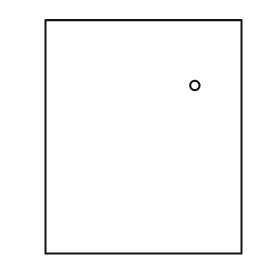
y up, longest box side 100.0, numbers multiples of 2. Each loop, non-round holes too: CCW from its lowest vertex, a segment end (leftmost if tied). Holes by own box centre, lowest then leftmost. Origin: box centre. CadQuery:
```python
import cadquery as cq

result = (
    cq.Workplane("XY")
    .moveTo(-42.0, -50.0)
    .lineTo(42.0, -50.0)
    .lineTo(42.0, 50.0)
    .lineTo(-42.0, 50.0)
    .close()
    .moveTo(22.0, 22.0)
    .circle(2.0)
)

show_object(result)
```